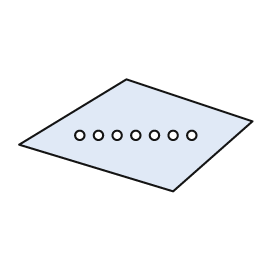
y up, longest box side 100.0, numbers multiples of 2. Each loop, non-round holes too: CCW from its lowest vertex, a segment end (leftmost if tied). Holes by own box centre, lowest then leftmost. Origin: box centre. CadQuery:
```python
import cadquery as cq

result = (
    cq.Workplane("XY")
    .moveTo(16.0, -24.0)
    .lineTo(50.0, 6.0)
    .lineTo(-4.0, 24.0)
    .lineTo(-50.0, -4.0)
    .close()
    .moveTo(-24.0, 0.0)
    .circle(2.0)
    .moveTo(-16.0, 0.0)
    .circle(2.0)
    .moveTo(-8.0, 0.0)
    .circle(2.0)
    .moveTo(0.0, 0.0)
    .circle(2.0)
    .moveTo(8.0, 0.0)
    .circle(2.0)
    .moveTo(16.0, 0.0)
    .circle(2.0)
    .moveTo(24.0, 0.0)
    .circle(2.0)
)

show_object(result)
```